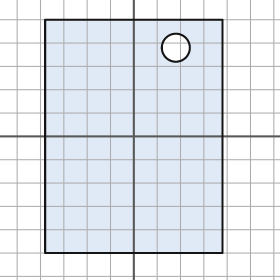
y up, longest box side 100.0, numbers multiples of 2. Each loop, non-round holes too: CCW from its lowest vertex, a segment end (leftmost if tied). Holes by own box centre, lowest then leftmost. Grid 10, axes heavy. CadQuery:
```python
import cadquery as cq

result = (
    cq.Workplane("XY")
    .moveTo(-38.0, -50.0)
    .lineTo(38.0, -50.0)
    .lineTo(38.0, 50.0)
    .lineTo(-38.0, 50.0)
    .close()
    .moveTo(18.0, 38.0)
    .circle(6.0)
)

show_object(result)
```